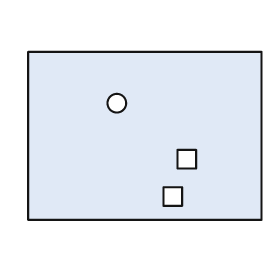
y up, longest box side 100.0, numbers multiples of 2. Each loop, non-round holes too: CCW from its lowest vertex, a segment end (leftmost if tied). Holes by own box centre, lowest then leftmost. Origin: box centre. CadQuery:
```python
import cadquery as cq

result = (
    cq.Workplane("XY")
    .moveTo(-50.0, -36.0)
    .lineTo(50.0, -36.0)
    .lineTo(50.0, 36.0)
    .lineTo(-50.0, 36.0)
    .close()
    .moveTo(8.0, -30.0)
    .lineTo(16.0, -30.0)
    .lineTo(16.0, -22.0)
    .lineTo(8.0, -22.0)
    .close()
    .moveTo(14.0, -14.0)
    .lineTo(22.0, -14.0)
    .lineTo(22.0, -6.0)
    .lineTo(14.0, -6.0)
    .close()
    .moveTo(-12.0, 14.0)
    .circle(4.0)
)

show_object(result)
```